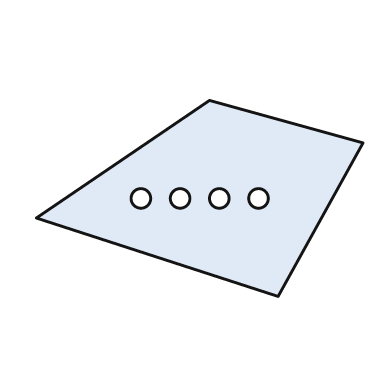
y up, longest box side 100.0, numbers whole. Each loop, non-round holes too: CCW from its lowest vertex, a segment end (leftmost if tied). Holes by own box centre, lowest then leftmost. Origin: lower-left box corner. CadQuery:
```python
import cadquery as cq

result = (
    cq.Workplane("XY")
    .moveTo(74.0, 0.0)
    .lineTo(100.0, 47.0)
    .lineTo(53.0, 60.0)
    .lineTo(0.0, 24.0)
    .close()
    .moveTo(32.0, 30.0)
    .circle(3.0)
    .moveTo(44.0, 30.0)
    .circle(3.0)
    .moveTo(56.0, 30.0)
    .circle(3.0)
    .moveTo(68.0, 30.0)
    .circle(3.0)
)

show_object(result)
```